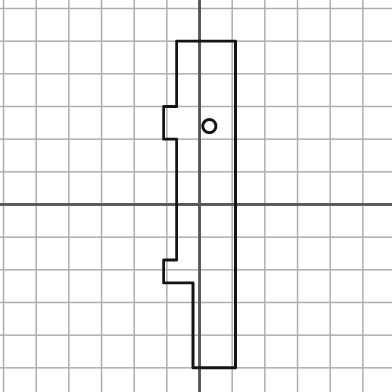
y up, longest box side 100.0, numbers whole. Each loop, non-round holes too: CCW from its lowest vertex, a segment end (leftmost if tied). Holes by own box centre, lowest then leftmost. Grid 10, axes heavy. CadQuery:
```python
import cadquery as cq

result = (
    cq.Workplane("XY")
    .moveTo(-2.0, -50.0)
    .lineTo(11.0, -50.0)
    .lineTo(11.0, 50.0)
    .lineTo(-7.0, 50.0)
    .lineTo(-7.0, 30.0)
    .lineTo(-11.0, 30.0)
    .lineTo(-11.0, 20.0)
    .lineTo(-7.0, 20.0)
    .lineTo(-7.0, -17.0)
    .lineTo(-11.0, -17.0)
    .lineTo(-11.0, -24.0)
    .lineTo(-2.0, -24.0)
    .close()
    .moveTo(3.0, 24.0)
    .circle(2.0)
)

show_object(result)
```